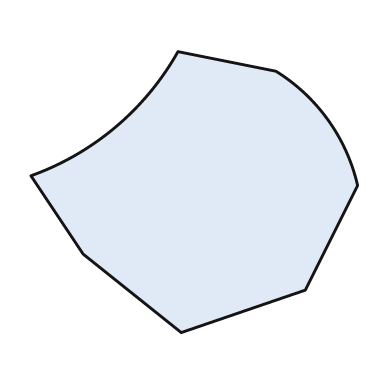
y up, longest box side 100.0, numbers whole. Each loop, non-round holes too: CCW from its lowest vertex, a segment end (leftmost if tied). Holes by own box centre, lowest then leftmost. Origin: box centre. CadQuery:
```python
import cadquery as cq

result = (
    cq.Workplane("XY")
    .moveTo(-4.0, -43.0)
    .lineTo(34.0, -30.0)
    .lineTo(50.0, 2.0)
    .threePointArc((41.0, 22.0), (25.0, 37.0))
    .lineTo(-5.0, 43.0)
    .threePointArc((-24.0, 20.0), (-50.0, 5.0))
    .lineTo(-34.0, -19.0)
    .close()
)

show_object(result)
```